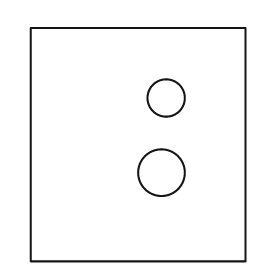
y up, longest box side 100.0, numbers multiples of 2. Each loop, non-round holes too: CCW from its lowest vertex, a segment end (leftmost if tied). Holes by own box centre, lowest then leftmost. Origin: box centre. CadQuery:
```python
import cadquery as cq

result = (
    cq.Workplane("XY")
    .moveTo(-46.0, -50.0)
    .lineTo(46.0, -50.0)
    .lineTo(46.0, 50.0)
    .lineTo(-46.0, 50.0)
    .close()
    .moveTo(10.0, -12.0)
    .circle(10.0)
    .moveTo(12.0, 20.0)
    .circle(8.0)
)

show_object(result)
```